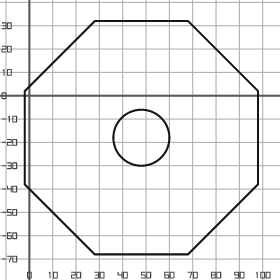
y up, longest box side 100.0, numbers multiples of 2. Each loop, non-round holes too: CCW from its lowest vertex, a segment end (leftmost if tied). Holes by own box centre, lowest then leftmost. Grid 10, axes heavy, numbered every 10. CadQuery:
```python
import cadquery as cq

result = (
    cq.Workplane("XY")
    .moveTo(28.0, -68.0)
    .lineTo(68.0, -68.0)
    .lineTo(98.0, -38.0)
    .lineTo(98.0, 2.0)
    .lineTo(68.0, 32.0)
    .lineTo(28.0, 32.0)
    .lineTo(-2.0, 2.0)
    .lineTo(-2.0, -38.0)
    .close()
    .moveTo(48.0, -18.0)
    .circle(12.0)
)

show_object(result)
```